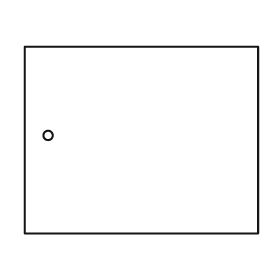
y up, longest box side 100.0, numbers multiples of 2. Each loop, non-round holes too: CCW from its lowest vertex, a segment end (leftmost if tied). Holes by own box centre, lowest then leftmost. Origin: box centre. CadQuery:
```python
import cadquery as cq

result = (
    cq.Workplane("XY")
    .moveTo(-50.0, -40.0)
    .lineTo(50.0, -40.0)
    .lineTo(50.0, 40.0)
    .lineTo(-50.0, 40.0)
    .close()
    .moveTo(-40.0, 2.0)
    .circle(2.0)
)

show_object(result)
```